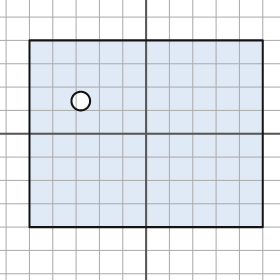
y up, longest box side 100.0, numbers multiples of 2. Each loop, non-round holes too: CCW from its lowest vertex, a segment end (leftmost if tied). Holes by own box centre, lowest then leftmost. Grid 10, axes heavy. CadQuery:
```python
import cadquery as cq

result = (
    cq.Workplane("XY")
    .moveTo(-50.0, -40.0)
    .lineTo(50.0, -40.0)
    .lineTo(50.0, 40.0)
    .lineTo(-50.0, 40.0)
    .close()
    .moveTo(-28.0, 14.0)
    .circle(4.0)
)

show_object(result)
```